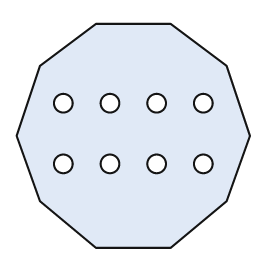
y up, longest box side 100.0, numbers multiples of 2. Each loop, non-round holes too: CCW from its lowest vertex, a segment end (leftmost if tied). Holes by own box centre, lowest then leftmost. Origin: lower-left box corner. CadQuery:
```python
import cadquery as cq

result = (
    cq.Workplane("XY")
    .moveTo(34.0, 0.0)
    .lineTo(66.0, 0.0)
    .lineTo(90.0, 20.0)
    .lineTo(100.0, 48.0)
    .lineTo(90.0, 78.0)
    .lineTo(66.0, 96.0)
    .lineTo(34.0, 96.0)
    .lineTo(10.0, 78.0)
    .lineTo(0.0, 48.0)
    .lineTo(10.0, 20.0)
    .close()
    .moveTo(20.0, 36.0)
    .circle(4.0)
    .moveTo(40.0, 36.0)
    .circle(4.0)
    .moveTo(60.0, 36.0)
    .circle(4.0)
    .moveTo(80.0, 36.0)
    .circle(4.0)
    .moveTo(20.0, 62.0)
    .circle(4.0)
    .moveTo(40.0, 62.0)
    .circle(4.0)
    .moveTo(60.0, 62.0)
    .circle(4.0)
    .moveTo(80.0, 62.0)
    .circle(4.0)
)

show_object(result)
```